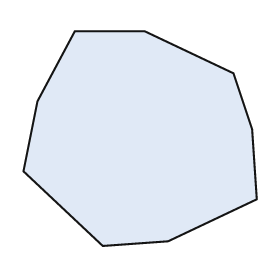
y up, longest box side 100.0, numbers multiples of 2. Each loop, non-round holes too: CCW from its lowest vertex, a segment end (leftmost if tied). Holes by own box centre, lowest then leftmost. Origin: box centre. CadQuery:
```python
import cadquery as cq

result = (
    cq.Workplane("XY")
    .moveTo(-16.0, -46.0)
    .lineTo(12.0, -44.0)
    .lineTo(50.0, -26.0)
    .lineTo(48.0, 4.0)
    .lineTo(40.0, 28.0)
    .lineTo(2.0, 46.0)
    .lineTo(-28.0, 46.0)
    .lineTo(-44.0, 16.0)
    .lineTo(-50.0, -14.0)
    .close()
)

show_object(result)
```